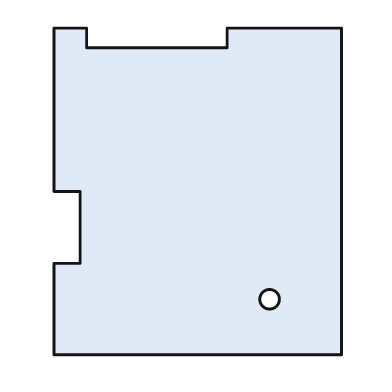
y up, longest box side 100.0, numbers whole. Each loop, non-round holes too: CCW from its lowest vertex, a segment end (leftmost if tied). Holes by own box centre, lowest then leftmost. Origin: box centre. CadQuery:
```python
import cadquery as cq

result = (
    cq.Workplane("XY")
    .moveTo(-44.0, -50.0)
    .lineTo(44.0, -50.0)
    .lineTo(44.0, 50.0)
    .lineTo(9.0, 50.0)
    .lineTo(9.0, 44.0)
    .lineTo(-34.0, 44.0)
    .lineTo(-34.0, 50.0)
    .lineTo(-44.0, 50.0)
    .lineTo(-44.0, 0.0)
    .lineTo(-36.0, 0.0)
    .lineTo(-36.0, -22.0)
    .lineTo(-44.0, -22.0)
    .close()
    .moveTo(22.0, -33.0)
    .circle(3.0)
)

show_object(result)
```